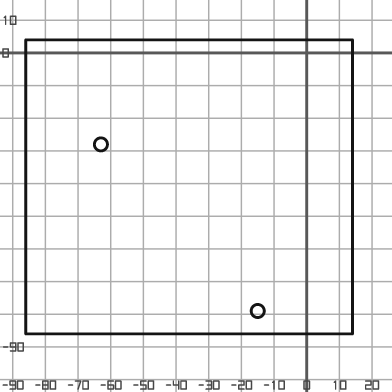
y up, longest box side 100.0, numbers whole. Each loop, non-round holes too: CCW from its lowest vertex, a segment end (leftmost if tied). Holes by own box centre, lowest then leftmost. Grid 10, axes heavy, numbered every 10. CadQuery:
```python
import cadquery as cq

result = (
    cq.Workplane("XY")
    .moveTo(-86.0, -86.0)
    .lineTo(14.0, -86.0)
    .lineTo(14.0, 4.0)
    .lineTo(-86.0, 4.0)
    .close()
    .moveTo(-15.0, -79.0)
    .circle(2.0)
    .moveTo(-63.0, -28.0)
    .circle(2.0)
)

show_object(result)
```